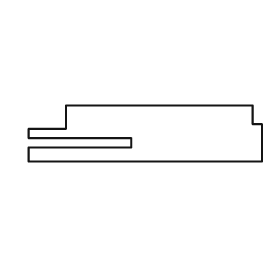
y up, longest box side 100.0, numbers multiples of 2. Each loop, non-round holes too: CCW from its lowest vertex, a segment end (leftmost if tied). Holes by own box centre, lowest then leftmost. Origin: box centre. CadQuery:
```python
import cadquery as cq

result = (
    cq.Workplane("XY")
    .moveTo(-50.0, -12.0)
    .lineTo(50.0, -12.0)
    .lineTo(50.0, 4.0)
    .lineTo(46.0, 4.0)
    .lineTo(46.0, 12.0)
    .lineTo(-34.0, 12.0)
    .lineTo(-34.0, 2.0)
    .lineTo(-50.0, 2.0)
    .lineTo(-50.0, -2.0)
    .lineTo(-6.0, -2.0)
    .lineTo(-6.0, -6.0)
    .lineTo(-50.0, -6.0)
    .close()
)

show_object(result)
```